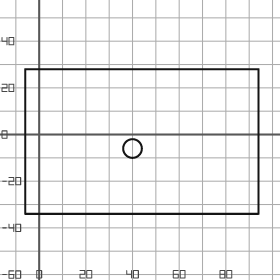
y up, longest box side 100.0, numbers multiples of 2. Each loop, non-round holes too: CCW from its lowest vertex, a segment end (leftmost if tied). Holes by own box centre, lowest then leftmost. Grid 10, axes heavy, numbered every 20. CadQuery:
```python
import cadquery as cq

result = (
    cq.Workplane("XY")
    .moveTo(-6.0, -34.0)
    .lineTo(94.0, -34.0)
    .lineTo(94.0, 28.0)
    .lineTo(-6.0, 28.0)
    .close()
    .moveTo(40.0, -6.0)
    .circle(4.0)
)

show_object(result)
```